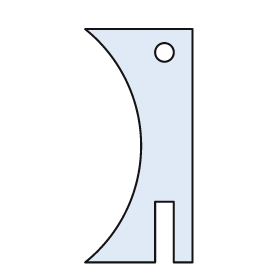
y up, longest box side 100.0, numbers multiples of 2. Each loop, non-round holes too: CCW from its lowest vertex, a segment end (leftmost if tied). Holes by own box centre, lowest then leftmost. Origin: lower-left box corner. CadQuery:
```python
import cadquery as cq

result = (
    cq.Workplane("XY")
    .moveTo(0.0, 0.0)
    .lineTo(30.0, 0.0)
    .lineTo(30.0, 26.0)
    .lineTo(38.0, 26.0)
    .lineTo(38.0, 0.0)
    .lineTo(46.0, 0.0)
    .lineTo(46.0, 100.0)
    .lineTo(0.0, 100.0)
    .threePointArc((24.0, 50.0), (0.0, 0.0))
    .close()
    .moveTo(34.0, 90.0)
    .circle(4.0)
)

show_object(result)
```